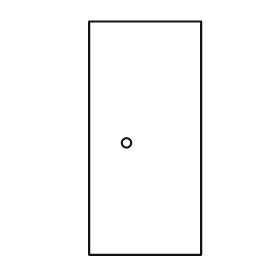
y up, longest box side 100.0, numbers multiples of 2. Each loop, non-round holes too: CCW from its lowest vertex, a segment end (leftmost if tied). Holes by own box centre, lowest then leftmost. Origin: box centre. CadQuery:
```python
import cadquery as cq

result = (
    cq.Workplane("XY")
    .moveTo(-24.0, -50.0)
    .lineTo(24.0, -50.0)
    .lineTo(24.0, 50.0)
    .lineTo(-24.0, 50.0)
    .close()
    .moveTo(-8.0, -2.0)
    .circle(2.0)
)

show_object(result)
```